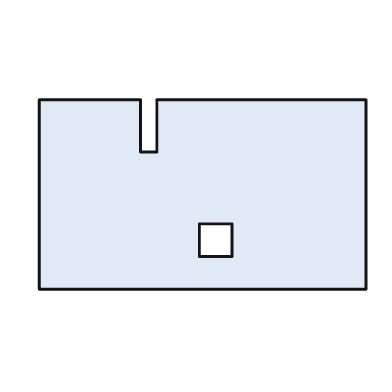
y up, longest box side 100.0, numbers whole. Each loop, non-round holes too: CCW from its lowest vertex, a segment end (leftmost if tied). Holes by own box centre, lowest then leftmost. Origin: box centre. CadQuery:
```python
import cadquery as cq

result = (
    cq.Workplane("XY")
    .moveTo(-50.0, -29.0)
    .lineTo(50.0, -29.0)
    .lineTo(50.0, 29.0)
    .lineTo(-14.0, 29.0)
    .lineTo(-14.0, 13.0)
    .lineTo(-19.0, 13.0)
    .lineTo(-19.0, 29.0)
    .lineTo(-50.0, 29.0)
    .close()
    .moveTo(-1.0, -19.0)
    .lineTo(9.0, -19.0)
    .lineTo(9.0, -9.0)
    .lineTo(-1.0, -9.0)
    .close()
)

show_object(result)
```